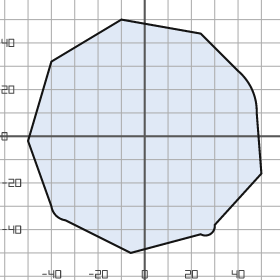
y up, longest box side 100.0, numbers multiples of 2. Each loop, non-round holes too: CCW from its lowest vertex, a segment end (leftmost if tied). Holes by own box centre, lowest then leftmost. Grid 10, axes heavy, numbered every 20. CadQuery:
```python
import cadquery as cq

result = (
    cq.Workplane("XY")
    .moveTo(-6.0, -50.0)
    .lineTo(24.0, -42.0)
    .threePointArc((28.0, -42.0), (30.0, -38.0))
    .lineTo(50.0, -16.0)
    .lineTo(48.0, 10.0)
    .threePointArc((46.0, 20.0), (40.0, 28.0))
    .lineTo(24.0, 44.0)
    .lineTo(-10.0, 50.0)
    .lineTo(-40.0, 32.0)
    .lineTo(-50.0, -2.0)
    .lineTo(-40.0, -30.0)
    .threePointArc((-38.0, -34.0), (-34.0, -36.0))
    .close()
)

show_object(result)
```